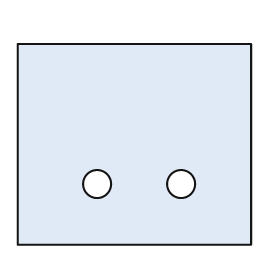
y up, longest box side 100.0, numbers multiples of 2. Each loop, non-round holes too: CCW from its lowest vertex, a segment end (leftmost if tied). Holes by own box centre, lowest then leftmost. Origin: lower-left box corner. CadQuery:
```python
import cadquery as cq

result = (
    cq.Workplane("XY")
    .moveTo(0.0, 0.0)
    .lineTo(100.0, 0.0)
    .lineTo(100.0, 86.0)
    .lineTo(0.0, 86.0)
    .close()
    .moveTo(34.0, 26.0)
    .circle(6.0)
    .moveTo(70.0, 26.0)
    .circle(6.0)
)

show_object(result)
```